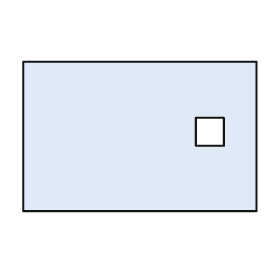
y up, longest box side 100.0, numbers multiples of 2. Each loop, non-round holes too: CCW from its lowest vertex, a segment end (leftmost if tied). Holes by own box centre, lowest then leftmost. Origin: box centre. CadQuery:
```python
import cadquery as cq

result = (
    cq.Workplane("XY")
    .moveTo(-50.0, -32.0)
    .lineTo(50.0, -32.0)
    .lineTo(50.0, 32.0)
    .lineTo(-50.0, 32.0)
    .close()
    .moveTo(24.0, -4.0)
    .lineTo(36.0, -4.0)
    .lineTo(36.0, 8.0)
    .lineTo(24.0, 8.0)
    .close()
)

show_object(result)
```